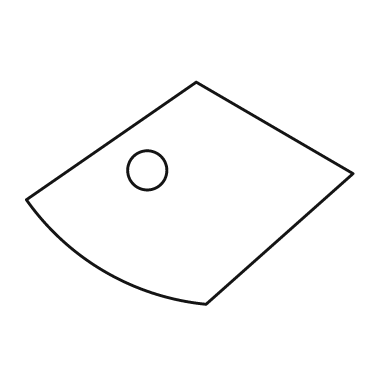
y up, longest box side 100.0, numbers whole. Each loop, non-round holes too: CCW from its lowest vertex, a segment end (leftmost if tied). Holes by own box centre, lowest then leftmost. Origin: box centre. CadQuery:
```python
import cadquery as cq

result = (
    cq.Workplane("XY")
    .moveTo(5.0, -34.0)
    .lineTo(50.0, 6.0)
    .lineTo(2.0, 34.0)
    .lineTo(-50.0, -2.0)
    .threePointArc((-26.0, -24.0), (5.0, -34.0))
    .close()
    .moveTo(-13.0, 7.0)
    .circle(6.0)
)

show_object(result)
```